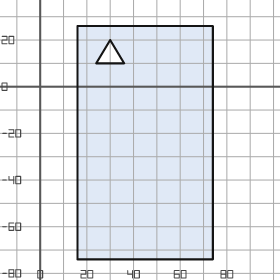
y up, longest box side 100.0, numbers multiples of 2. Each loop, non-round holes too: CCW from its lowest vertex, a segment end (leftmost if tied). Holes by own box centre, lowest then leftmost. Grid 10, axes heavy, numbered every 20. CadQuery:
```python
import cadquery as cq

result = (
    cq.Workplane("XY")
    .moveTo(16.0, -74.0)
    .lineTo(74.0, -74.0)
    .lineTo(74.0, 26.0)
    .lineTo(16.0, 26.0)
    .close()
    .moveTo(24.0, 10.0)
    .lineTo(36.0, 10.0)
    .lineTo(30.0, 20.0)
    .close()
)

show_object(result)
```